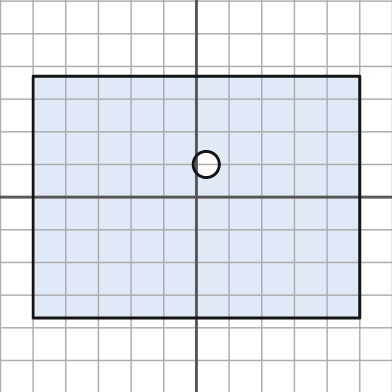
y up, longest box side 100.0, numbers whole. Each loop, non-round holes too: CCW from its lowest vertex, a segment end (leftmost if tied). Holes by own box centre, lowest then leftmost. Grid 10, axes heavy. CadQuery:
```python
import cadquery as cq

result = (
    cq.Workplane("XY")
    .moveTo(-50.0, -37.0)
    .lineTo(50.0, -37.0)
    .lineTo(50.0, 37.0)
    .lineTo(-50.0, 37.0)
    .close()
    .moveTo(3.0, 10.0)
    .circle(4.0)
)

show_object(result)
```